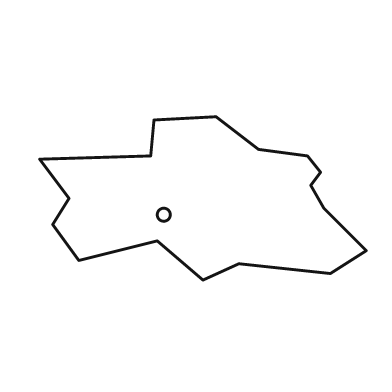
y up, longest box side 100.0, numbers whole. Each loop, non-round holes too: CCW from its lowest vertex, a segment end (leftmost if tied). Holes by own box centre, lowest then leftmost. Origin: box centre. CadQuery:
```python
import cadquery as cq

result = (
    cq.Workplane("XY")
    .moveTo(0.0, -25.0)
    .lineTo(11.0, -20.0)
    .lineTo(39.0, -23.0)
    .lineTo(50.0, -16.0)
    .lineTo(37.0, -3.0)
    .lineTo(33.0, 4.0)
    .lineTo(36.0, 8.0)
    .lineTo(32.0, 13.0)
    .lineTo(17.0, 15.0)
    .lineTo(4.0, 25.0)
    .lineTo(-15.0, 24.0)
    .lineTo(-16.0, 13.0)
    .lineTo(-50.0, 12.0)
    .lineTo(-41.0, 0.0)
    .lineTo(-46.0, -8.0)
    .lineTo(-38.0, -19.0)
    .lineTo(-14.0, -13.0)
    .close()
    .moveTo(-12.0, -5.0)
    .circle(2.0)
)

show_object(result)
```